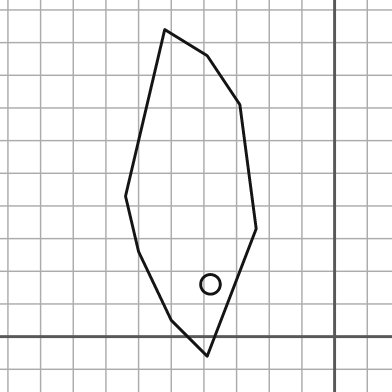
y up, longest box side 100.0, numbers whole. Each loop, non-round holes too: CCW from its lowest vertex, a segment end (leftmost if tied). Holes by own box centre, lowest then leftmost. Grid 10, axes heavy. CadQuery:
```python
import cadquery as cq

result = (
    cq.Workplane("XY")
    .moveTo(-39.0, -6.0)
    .lineTo(-24.0, 33.0)
    .lineTo(-29.0, 71.0)
    .lineTo(-39.0, 86.0)
    .lineTo(-52.0, 94.0)
    .lineTo(-64.0, 43.0)
    .lineTo(-60.0, 26.0)
    .lineTo(-50.0, 5.0)
    .close()
    .moveTo(-38.0, 16.0)
    .circle(3.0)
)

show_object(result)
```